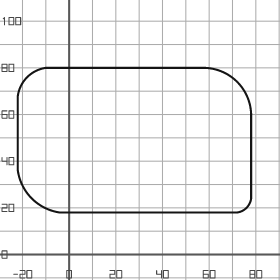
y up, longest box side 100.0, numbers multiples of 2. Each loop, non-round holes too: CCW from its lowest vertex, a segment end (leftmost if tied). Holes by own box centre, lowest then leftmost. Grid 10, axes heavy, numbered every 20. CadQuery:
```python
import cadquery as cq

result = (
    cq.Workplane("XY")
    .moveTo(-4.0, 18.0)
    .lineTo(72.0, 18.0)
    .threePointArc((76.0, 20.0), (78.0, 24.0))
    .lineTo(78.0, 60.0)
    .threePointArc((72.0, 74.0), (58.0, 80.0))
    .lineTo(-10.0, 80.0)
    .threePointArc((-18.0, 76.0), (-22.0, 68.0))
    .lineTo(-22.0, 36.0)
    .threePointArc((-16.0, 24.0), (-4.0, 18.0))
    .close()
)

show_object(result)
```